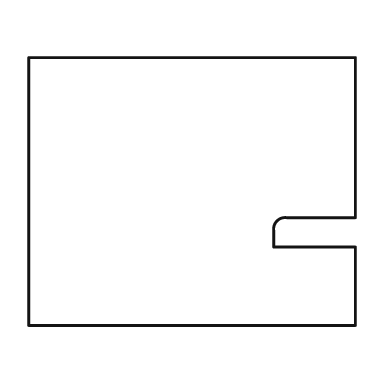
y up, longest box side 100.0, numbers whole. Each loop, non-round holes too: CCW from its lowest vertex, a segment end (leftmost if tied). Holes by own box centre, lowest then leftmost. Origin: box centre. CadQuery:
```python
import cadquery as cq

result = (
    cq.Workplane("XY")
    .moveTo(-50.0, -41.0)
    .lineTo(50.0, -41.0)
    .lineTo(50.0, -17.0)
    .lineTo(25.0, -17.0)
    .lineTo(25.0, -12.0)
    .threePointArc((26.0, -9.0), (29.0, -8.0))
    .lineTo(50.0, -8.0)
    .lineTo(50.0, 41.0)
    .lineTo(-50.0, 41.0)
    .close()
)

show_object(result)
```